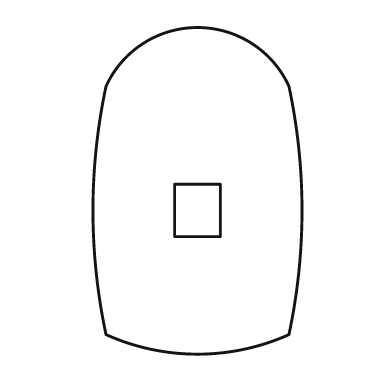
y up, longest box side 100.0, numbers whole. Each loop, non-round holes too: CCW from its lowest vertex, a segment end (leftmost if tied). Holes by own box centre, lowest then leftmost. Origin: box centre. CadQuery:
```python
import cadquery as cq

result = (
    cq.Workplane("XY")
    .moveTo(-28.0, -44.0)
    .threePointArc((0.0, -50.0), (28.0, -44.0))
    .threePointArc((32.0, -6.0), (28.0, 32.0))
    .threePointArc((0.0, 50.0), (-28.0, 32.0))
    .threePointArc((-32.0, -6.0), (-28.0, -44.0))
    .close()
    .moveTo(-7.0, -14.0)
    .lineTo(7.0, -14.0)
    .lineTo(7.0, 2.0)
    .lineTo(-7.0, 2.0)
    .close()
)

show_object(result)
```